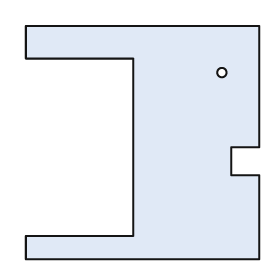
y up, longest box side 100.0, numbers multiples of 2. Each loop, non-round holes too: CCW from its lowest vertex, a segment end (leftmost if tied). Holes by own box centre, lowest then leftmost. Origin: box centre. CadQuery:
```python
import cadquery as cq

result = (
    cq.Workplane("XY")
    .moveTo(-50.0, -50.0)
    .lineTo(50.0, -50.0)
    .lineTo(50.0, -14.0)
    .lineTo(38.0, -14.0)
    .lineTo(38.0, -2.0)
    .lineTo(50.0, -2.0)
    .lineTo(50.0, 50.0)
    .lineTo(-50.0, 50.0)
    .lineTo(-50.0, 36.0)
    .lineTo(-4.0, 36.0)
    .lineTo(-4.0, -40.0)
    .lineTo(-50.0, -40.0)
    .close()
    .moveTo(34.0, 30.0)
    .circle(2.0)
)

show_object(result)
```